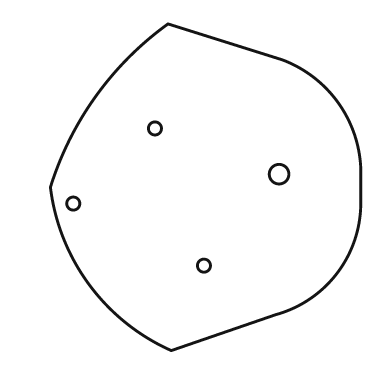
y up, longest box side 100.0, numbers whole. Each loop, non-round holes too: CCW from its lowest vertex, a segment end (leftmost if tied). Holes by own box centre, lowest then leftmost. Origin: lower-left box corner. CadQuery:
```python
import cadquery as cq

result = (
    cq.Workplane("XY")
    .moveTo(37.0, 0.0)
    .lineTo(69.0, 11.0)
    .threePointArc((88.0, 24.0), (95.0, 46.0))
    .lineTo(95.0, 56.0)
    .threePointArc((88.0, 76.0), (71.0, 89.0))
    .lineTo(36.0, 100.0)
    .threePointArc((14.0, 78.0), (0.0, 50.0))
    .threePointArc((12.0, 20.0), (37.0, 0.0))
    .close()
    .moveTo(47.0, 26.0)
    .circle(2.0)
    .moveTo(7.0, 45.0)
    .circle(2.0)
    .moveTo(70.0, 54.0)
    .circle(3.0)
    .moveTo(32.0, 68.0)
    .circle(2.0)
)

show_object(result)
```